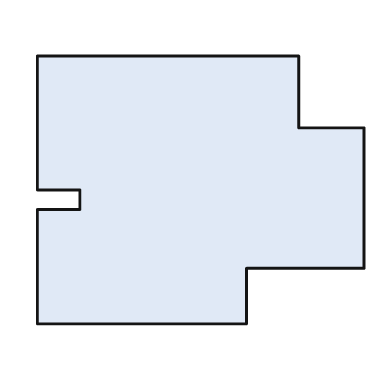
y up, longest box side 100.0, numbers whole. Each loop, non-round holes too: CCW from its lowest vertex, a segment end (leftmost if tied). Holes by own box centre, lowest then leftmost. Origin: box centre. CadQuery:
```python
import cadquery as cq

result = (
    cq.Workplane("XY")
    .moveTo(-50.0, -41.0)
    .lineTo(14.0, -41.0)
    .lineTo(14.0, -24.0)
    .lineTo(50.0, -24.0)
    .lineTo(50.0, 19.0)
    .lineTo(30.0, 19.0)
    .lineTo(30.0, 41.0)
    .lineTo(-50.0, 41.0)
    .lineTo(-50.0, 0.0)
    .lineTo(-37.0, 0.0)
    .lineTo(-37.0, -6.0)
    .lineTo(-50.0, -6.0)
    .close()
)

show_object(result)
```